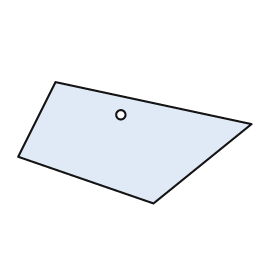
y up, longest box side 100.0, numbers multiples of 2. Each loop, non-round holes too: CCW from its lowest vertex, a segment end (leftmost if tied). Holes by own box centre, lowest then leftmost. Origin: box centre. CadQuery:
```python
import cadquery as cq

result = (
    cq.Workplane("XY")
    .moveTo(8.0, -26.0)
    .lineTo(50.0, 8.0)
    .lineTo(-34.0, 26.0)
    .lineTo(-50.0, -6.0)
    .close()
    .moveTo(-6.0, 12.0)
    .circle(2.0)
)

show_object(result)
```